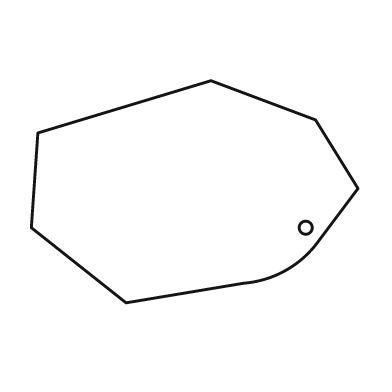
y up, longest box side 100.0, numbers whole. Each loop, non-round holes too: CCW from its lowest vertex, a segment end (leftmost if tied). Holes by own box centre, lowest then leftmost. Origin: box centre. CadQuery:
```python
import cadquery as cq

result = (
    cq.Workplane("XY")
    .moveTo(-21.0, -34.0)
    .lineTo(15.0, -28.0)
    .threePointArc((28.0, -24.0), (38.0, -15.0))
    .lineTo(50.0, 1.0)
    .lineTo(37.0, 22.0)
    .lineTo(5.0, 34.0)
    .lineTo(-48.0, 18.0)
    .lineTo(-50.0, -11.0)
    .close()
    .moveTo(34.0, -11.0)
    .circle(2.0)
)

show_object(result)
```